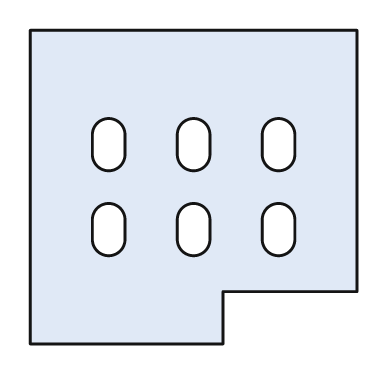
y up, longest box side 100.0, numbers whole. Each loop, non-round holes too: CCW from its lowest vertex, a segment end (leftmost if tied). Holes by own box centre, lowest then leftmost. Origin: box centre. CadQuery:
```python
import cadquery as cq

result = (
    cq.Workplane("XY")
    .moveTo(-50.0, -48.0)
    .lineTo(9.0, -48.0)
    .lineTo(9.0, -32.0)
    .lineTo(50.0, -32.0)
    .lineTo(50.0, 48.0)
    .lineTo(-50.0, 48.0)
    .close()
    .moveTo(-31.0, -16.0)
    .threePointArc((-26.0, -21.0), (-21.0, -16.0))
    .lineTo(-21.0, -10.0)
    .threePointArc((-26.0, -5.0), (-31.0, -10.0))
    .close()
    .moveTo(-5.0, -16.0)
    .threePointArc((0.0, -21.0), (5.0, -16.0))
    .lineTo(5.0, -10.0)
    .threePointArc((0.0, -5.0), (-5.0, -10.0))
    .close()
    .moveTo(21.0, -16.0)
    .threePointArc((26.0, -21.0), (31.0, -16.0))
    .lineTo(31.0, -10.0)
    .threePointArc((26.0, -5.0), (21.0, -10.0))
    .close()
    .moveTo(-31.0, 10.0)
    .threePointArc((-26.0, 5.0), (-21.0, 10.0))
    .lineTo(-21.0, 16.0)
    .threePointArc((-26.0, 21.0), (-31.0, 16.0))
    .close()
    .moveTo(-5.0, 10.0)
    .threePointArc((0.0, 5.0), (5.0, 10.0))
    .lineTo(5.0, 16.0)
    .threePointArc((0.0, 21.0), (-5.0, 16.0))
    .close()
    .moveTo(21.0, 10.0)
    .threePointArc((26.0, 5.0), (31.0, 10.0))
    .lineTo(31.0, 16.0)
    .threePointArc((26.0, 21.0), (21.0, 16.0))
    .close()
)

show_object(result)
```